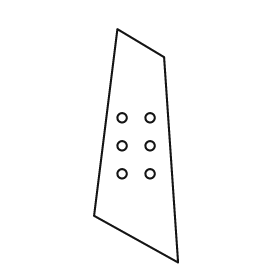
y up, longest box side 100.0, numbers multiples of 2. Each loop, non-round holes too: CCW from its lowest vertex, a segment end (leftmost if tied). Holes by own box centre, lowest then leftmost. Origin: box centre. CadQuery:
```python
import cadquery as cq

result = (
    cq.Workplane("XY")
    .moveTo(18.0, -50.0)
    .lineTo(12.0, 38.0)
    .lineTo(-8.0, 50.0)
    .lineTo(-18.0, -30.0)
    .close()
    .moveTo(-6.0, -12.0)
    .circle(2.0)
    .moveTo(6.0, -12.0)
    .circle(2.0)
    .moveTo(-6.0, 0.0)
    .circle(2.0)
    .moveTo(6.0, 0.0)
    .circle(2.0)
    .moveTo(-6.0, 12.0)
    .circle(2.0)
    .moveTo(6.0, 12.0)
    .circle(2.0)
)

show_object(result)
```